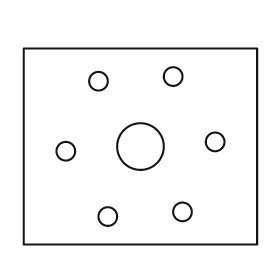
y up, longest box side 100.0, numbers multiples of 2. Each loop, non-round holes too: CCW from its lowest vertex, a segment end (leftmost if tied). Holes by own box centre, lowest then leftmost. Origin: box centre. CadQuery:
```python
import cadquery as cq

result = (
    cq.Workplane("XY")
    .moveTo(-50.0, -42.0)
    .lineTo(50.0, -42.0)
    .lineTo(50.0, 42.0)
    .lineTo(-50.0, 42.0)
    .close()
    .moveTo(-14.0, -30.0)
    .circle(4.0)
    .moveTo(18.0, -28.0)
    .circle(4.0)
    .moveTo(-32.0, -2.0)
    .circle(4.0)
    .moveTo(0.0, 0.0)
    .circle(10.0)
    .moveTo(32.0, 2.0)
    .circle(4.0)
    .moveTo(-18.0, 28.0)
    .circle(4.0)
    .moveTo(14.0, 30.0)
    .circle(4.0)
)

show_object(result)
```